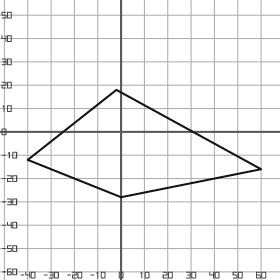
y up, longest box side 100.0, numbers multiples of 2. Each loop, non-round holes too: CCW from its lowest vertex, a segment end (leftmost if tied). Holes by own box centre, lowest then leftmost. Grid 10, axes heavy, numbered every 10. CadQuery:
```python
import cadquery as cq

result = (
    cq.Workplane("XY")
    .moveTo(0.0, -28.0)
    .lineTo(60.0, -16.0)
    .lineTo(-2.0, 18.0)
    .lineTo(-40.0, -12.0)
    .close()
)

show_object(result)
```